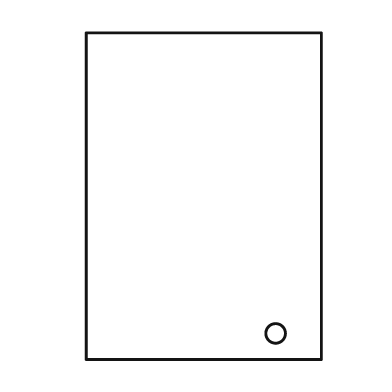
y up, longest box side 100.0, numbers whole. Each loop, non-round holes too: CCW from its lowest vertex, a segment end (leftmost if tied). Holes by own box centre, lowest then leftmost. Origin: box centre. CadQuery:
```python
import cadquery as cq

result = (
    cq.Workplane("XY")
    .moveTo(-36.0, -50.0)
    .lineTo(36.0, -50.0)
    .lineTo(36.0, 50.0)
    .lineTo(-36.0, 50.0)
    .close()
    .moveTo(22.0, -42.0)
    .circle(3.0)
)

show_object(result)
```